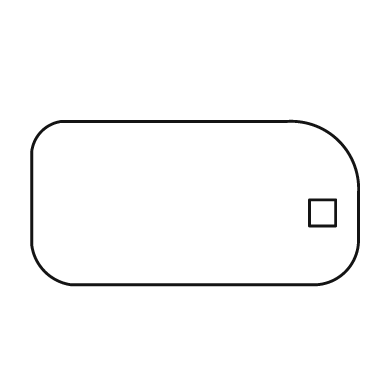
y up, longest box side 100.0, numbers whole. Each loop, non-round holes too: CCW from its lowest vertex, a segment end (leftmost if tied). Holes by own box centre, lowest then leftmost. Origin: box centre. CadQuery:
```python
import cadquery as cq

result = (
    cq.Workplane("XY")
    .moveTo(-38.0, -25.0)
    .lineTo(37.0, -25.0)
    .threePointArc((46.0, -21.0), (50.0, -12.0))
    .lineTo(50.0, 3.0)
    .threePointArc((44.0, 19.0), (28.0, 25.0))
    .lineTo(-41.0, 25.0)
    .threePointArc((-47.0, 22.0), (-50.0, 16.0))
    .lineTo(-50.0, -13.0)
    .threePointArc((-46.0, -21.0), (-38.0, -25.0))
    .close()
    .moveTo(35.0, -7.0)
    .lineTo(43.0, -7.0)
    .lineTo(43.0, 1.0)
    .lineTo(35.0, 1.0)
    .close()
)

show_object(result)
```